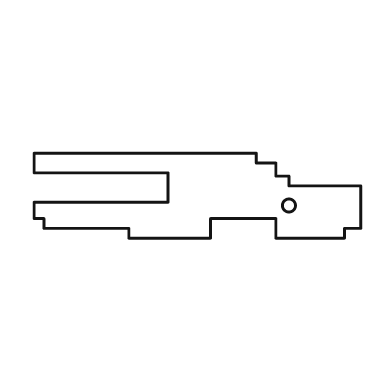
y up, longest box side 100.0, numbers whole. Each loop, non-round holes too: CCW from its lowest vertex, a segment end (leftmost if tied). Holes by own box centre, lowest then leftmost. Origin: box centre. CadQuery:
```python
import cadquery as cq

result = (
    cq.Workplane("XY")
    .moveTo(-21.0, -13.0)
    .lineTo(4.0, -13.0)
    .lineTo(4.0, -7.0)
    .lineTo(24.0, -7.0)
    .lineTo(24.0, -13.0)
    .lineTo(45.0, -13.0)
    .lineTo(45.0, -10.0)
    .lineTo(50.0, -10.0)
    .lineTo(50.0, 3.0)
    .lineTo(28.0, 3.0)
    .lineTo(28.0, 6.0)
    .lineTo(24.0, 6.0)
    .lineTo(24.0, 10.0)
    .lineTo(18.0, 10.0)
    .lineTo(18.0, 13.0)
    .lineTo(-50.0, 13.0)
    .lineTo(-50.0, 7.0)
    .lineTo(-9.0, 7.0)
    .lineTo(-9.0, -2.0)
    .lineTo(-50.0, -2.0)
    .lineTo(-50.0, -7.0)
    .lineTo(-47.0, -7.0)
    .lineTo(-47.0, -10.0)
    .lineTo(-21.0, -10.0)
    .close()
    .moveTo(28.0, -3.0)
    .circle(2.0)
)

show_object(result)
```